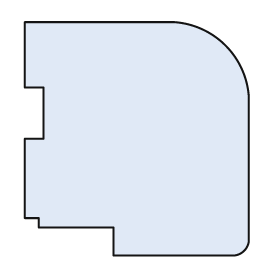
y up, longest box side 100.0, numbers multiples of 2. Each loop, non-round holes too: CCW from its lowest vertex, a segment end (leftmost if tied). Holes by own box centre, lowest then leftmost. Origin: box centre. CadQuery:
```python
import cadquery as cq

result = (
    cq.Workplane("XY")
    .moveTo(-10.0, -50.0)
    .lineTo(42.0, -50.0)
    .threePointArc((46.0, -48.0), (48.0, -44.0))
    .lineTo(48.0, 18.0)
    .threePointArc((38.0, 40.0), (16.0, 50.0))
    .lineTo(-48.0, 50.0)
    .lineTo(-48.0, 22.0)
    .lineTo(-40.0, 22.0)
    .lineTo(-40.0, 0.0)
    .lineTo(-48.0, 0.0)
    .lineTo(-48.0, -34.0)
    .lineTo(-42.0, -34.0)
    .lineTo(-42.0, -38.0)
    .lineTo(-10.0, -38.0)
    .close()
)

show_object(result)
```